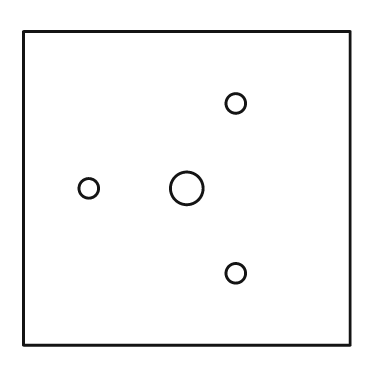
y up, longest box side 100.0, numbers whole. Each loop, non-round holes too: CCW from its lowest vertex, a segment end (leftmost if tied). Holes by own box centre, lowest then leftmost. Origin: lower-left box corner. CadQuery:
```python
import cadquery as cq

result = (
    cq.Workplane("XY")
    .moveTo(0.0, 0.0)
    .lineTo(100.0, 0.0)
    .lineTo(100.0, 96.0)
    .lineTo(0.0, 96.0)
    .close()
    .moveTo(65.0, 22.0)
    .circle(3.0)
    .moveTo(20.0, 48.0)
    .circle(3.0)
    .moveTo(50.0, 48.0)
    .circle(5.0)
    .moveTo(65.0, 74.0)
    .circle(3.0)
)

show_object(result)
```